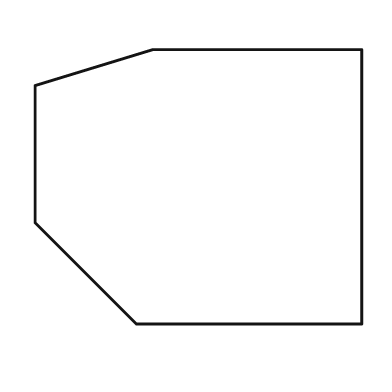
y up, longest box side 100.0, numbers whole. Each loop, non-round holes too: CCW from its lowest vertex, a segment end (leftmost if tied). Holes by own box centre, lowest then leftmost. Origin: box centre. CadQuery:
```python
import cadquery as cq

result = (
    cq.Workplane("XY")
    .moveTo(-19.0, -42.0)
    .lineTo(50.0, -42.0)
    .lineTo(50.0, 42.0)
    .lineTo(-14.0, 42.0)
    .lineTo(-50.0, 31.0)
    .lineTo(-50.0, -11.0)
    .close()
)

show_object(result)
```